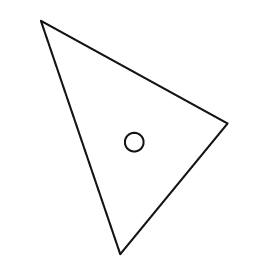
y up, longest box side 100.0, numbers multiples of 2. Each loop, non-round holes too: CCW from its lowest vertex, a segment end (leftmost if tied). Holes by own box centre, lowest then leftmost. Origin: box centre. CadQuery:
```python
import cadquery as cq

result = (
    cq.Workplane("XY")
    .moveTo(-6.0, -50.0)
    .lineTo(40.0, 6.0)
    .lineTo(-40.0, 50.0)
    .close()
    .moveTo(0.0, -2.0)
    .circle(4.0)
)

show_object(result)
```